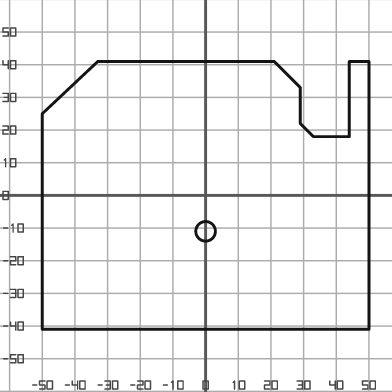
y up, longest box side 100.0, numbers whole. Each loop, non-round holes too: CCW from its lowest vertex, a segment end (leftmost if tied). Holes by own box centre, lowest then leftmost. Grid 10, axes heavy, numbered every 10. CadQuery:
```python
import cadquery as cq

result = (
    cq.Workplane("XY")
    .moveTo(-50.0, -41.0)
    .lineTo(50.0, -41.0)
    .lineTo(50.0, 41.0)
    .lineTo(44.0, 41.0)
    .lineTo(44.0, 18.0)
    .lineTo(33.0, 18.0)
    .lineTo(29.0, 22.0)
    .lineTo(29.0, 33.0)
    .lineTo(21.0, 41.0)
    .lineTo(-33.0, 41.0)
    .lineTo(-50.0, 25.0)
    .close()
    .moveTo(0.0, -11.0)
    .circle(3.0)
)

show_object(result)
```